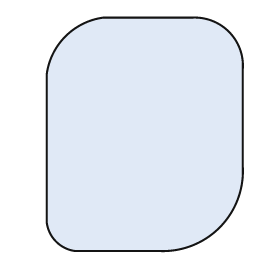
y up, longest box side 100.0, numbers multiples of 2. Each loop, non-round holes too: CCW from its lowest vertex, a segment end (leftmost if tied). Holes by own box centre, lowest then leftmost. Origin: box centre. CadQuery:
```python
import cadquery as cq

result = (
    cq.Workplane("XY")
    .moveTo(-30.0, -50.0)
    .lineTo(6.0, -50.0)
    .threePointArc((32.0, -40.0), (42.0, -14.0))
    .lineTo(42.0, 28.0)
    .threePointArc((36.0, 44.0), (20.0, 50.0))
    .lineTo(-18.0, 50.0)
    .threePointArc((-34.0, 42.0), (-42.0, 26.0))
    .lineTo(-42.0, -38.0)
    .threePointArc((-38.0, -46.0), (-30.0, -50.0))
    .close()
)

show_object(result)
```